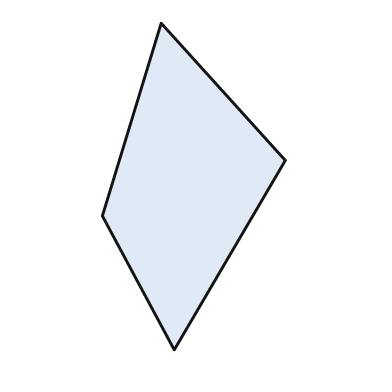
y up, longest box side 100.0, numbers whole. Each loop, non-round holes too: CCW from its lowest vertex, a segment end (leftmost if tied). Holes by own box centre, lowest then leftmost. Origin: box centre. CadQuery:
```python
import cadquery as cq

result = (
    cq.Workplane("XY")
    .moveTo(-6.0, -50.0)
    .lineTo(28.0, 8.0)
    .lineTo(-10.0, 50.0)
    .lineTo(-28.0, -9.0)
    .close()
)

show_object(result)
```